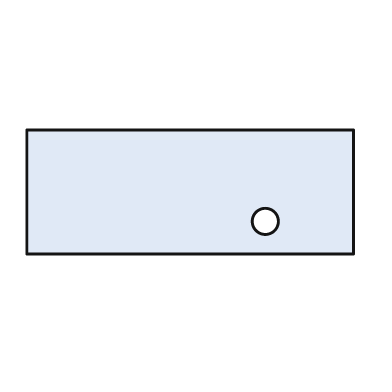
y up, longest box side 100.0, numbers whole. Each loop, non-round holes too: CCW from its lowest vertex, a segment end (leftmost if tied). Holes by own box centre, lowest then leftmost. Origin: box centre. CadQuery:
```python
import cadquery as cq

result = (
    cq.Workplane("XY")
    .moveTo(-50.0, -19.0)
    .lineTo(50.0, -19.0)
    .lineTo(50.0, 19.0)
    .lineTo(-50.0, 19.0)
    .close()
    .moveTo(23.0, -9.0)
    .circle(4.0)
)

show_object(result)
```